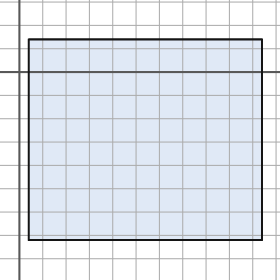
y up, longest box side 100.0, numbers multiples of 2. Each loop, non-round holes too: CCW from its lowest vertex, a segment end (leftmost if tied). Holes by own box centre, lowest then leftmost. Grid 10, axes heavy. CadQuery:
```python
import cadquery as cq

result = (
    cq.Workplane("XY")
    .moveTo(4.0, -72.0)
    .lineTo(104.0, -72.0)
    .lineTo(104.0, 14.0)
    .lineTo(4.0, 14.0)
    .close()
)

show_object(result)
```